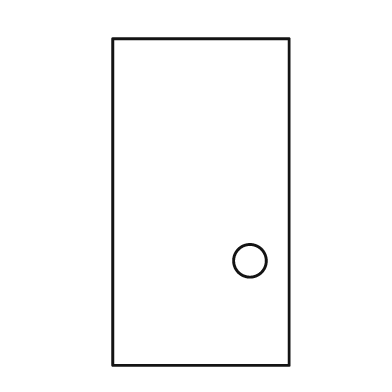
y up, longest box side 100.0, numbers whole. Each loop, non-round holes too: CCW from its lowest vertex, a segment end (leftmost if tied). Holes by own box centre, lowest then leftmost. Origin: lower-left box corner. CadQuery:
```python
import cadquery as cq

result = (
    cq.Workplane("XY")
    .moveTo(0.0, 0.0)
    .lineTo(54.0, 0.0)
    .lineTo(54.0, 100.0)
    .lineTo(0.0, 100.0)
    .close()
    .moveTo(42.0, 32.0)
    .circle(5.0)
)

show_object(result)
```